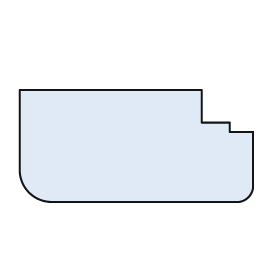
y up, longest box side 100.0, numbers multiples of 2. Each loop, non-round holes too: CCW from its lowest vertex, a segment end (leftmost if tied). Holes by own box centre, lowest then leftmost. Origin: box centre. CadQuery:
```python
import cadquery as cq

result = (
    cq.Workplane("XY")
    .moveTo(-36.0, -24.0)
    .lineTo(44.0, -24.0)
    .threePointArc((48.0, -22.0), (50.0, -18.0))
    .lineTo(50.0, 6.0)
    .lineTo(40.0, 6.0)
    .lineTo(40.0, 10.0)
    .lineTo(28.0, 10.0)
    .lineTo(28.0, 24.0)
    .lineTo(-50.0, 24.0)
    .lineTo(-50.0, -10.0)
    .threePointArc((-46.0, -20.0), (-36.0, -24.0))
    .close()
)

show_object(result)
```